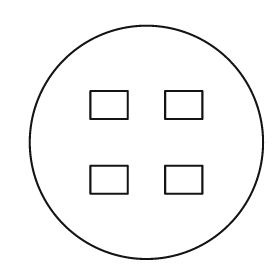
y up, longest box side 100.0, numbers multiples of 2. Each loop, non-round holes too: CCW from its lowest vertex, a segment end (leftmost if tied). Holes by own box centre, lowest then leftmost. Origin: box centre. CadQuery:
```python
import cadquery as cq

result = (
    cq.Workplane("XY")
    .moveTo(0.0, 0.0)
    .circle(50.0)
    .moveTo(-24.0, -22.0)
    .lineTo(-8.0, -22.0)
    .lineTo(-8.0, -10.0)
    .lineTo(-24.0, -10.0)
    .close()
    .moveTo(8.0, -22.0)
    .lineTo(24.0, -22.0)
    .lineTo(24.0, -10.0)
    .lineTo(8.0, -10.0)
    .close()
    .moveTo(-24.0, 10.0)
    .lineTo(-8.0, 10.0)
    .lineTo(-8.0, 22.0)
    .lineTo(-24.0, 22.0)
    .close()
    .moveTo(8.0, 10.0)
    .lineTo(24.0, 10.0)
    .lineTo(24.0, 22.0)
    .lineTo(8.0, 22.0)
    .close()
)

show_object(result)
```